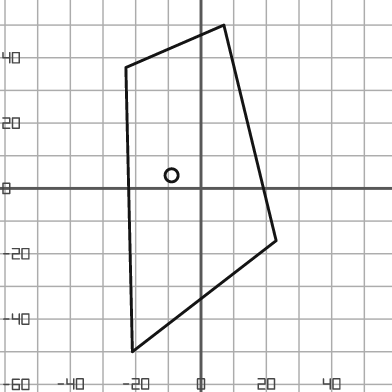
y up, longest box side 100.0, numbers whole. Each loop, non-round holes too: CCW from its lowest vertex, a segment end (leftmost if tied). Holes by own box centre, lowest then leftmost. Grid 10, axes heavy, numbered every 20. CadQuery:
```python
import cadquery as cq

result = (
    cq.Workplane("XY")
    .moveTo(-21.0, -50.0)
    .lineTo(23.0, -16.0)
    .lineTo(7.0, 50.0)
    .lineTo(-23.0, 37.0)
    .close()
    .moveTo(-9.0, 4.0)
    .circle(2.0)
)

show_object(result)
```